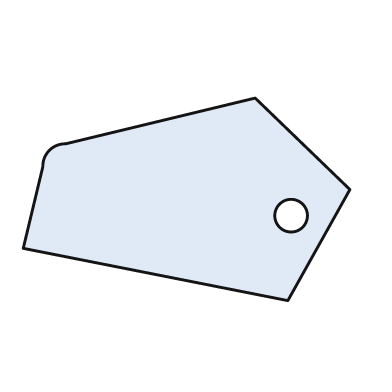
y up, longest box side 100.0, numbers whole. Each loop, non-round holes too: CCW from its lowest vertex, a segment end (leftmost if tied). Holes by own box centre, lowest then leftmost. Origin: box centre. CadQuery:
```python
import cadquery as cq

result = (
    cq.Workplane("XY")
    .moveTo(31.0, -31.0)
    .lineTo(50.0, 3.0)
    .lineTo(21.0, 31.0)
    .lineTo(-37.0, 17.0)
    .threePointArc((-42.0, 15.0), (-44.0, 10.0))
    .lineTo(-50.0, -15.0)
    .close()
    .moveTo(32.0, -5.0)
    .circle(5.0)
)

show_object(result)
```